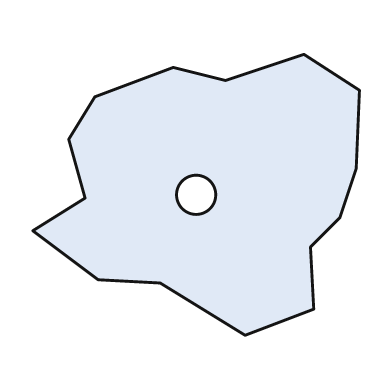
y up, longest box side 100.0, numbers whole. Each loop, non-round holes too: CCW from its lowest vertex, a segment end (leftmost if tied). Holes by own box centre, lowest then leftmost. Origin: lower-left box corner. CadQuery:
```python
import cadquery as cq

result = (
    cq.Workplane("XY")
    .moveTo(65.0, 0.0)
    .lineTo(86.0, 8.0)
    .lineTo(85.0, 27.0)
    .lineTo(94.0, 36.0)
    .lineTo(99.0, 51.0)
    .lineTo(100.0, 75.0)
    .lineTo(83.0, 86.0)
    .lineTo(59.0, 78.0)
    .lineTo(43.0, 82.0)
    .lineTo(19.0, 73.0)
    .lineTo(11.0, 60.0)
    .lineTo(16.0, 42.0)
    .lineTo(0.0, 32.0)
    .lineTo(20.0, 17.0)
    .lineTo(39.0, 16.0)
    .close()
    .moveTo(50.0, 43.0)
    .circle(6.0)
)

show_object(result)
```